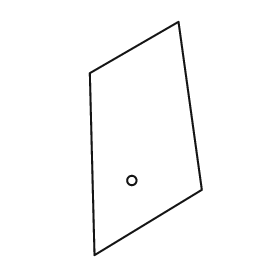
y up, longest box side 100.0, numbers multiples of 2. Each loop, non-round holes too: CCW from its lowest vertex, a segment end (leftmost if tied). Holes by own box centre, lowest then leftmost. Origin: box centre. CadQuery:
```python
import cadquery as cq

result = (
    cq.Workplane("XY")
    .moveTo(-22.0, -50.0)
    .lineTo(24.0, -22.0)
    .lineTo(14.0, 50.0)
    .lineTo(-24.0, 28.0)
    .close()
    .moveTo(-6.0, -18.0)
    .circle(2.0)
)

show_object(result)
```